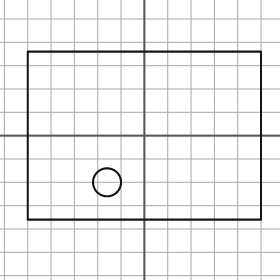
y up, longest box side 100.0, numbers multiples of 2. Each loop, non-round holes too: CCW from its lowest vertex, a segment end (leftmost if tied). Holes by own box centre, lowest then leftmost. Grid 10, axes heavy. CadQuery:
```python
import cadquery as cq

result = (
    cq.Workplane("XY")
    .moveTo(-50.0, -36.0)
    .lineTo(50.0, -36.0)
    .lineTo(50.0, 36.0)
    .lineTo(-50.0, 36.0)
    .close()
    .moveTo(-16.0, -20.0)
    .circle(6.0)
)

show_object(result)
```